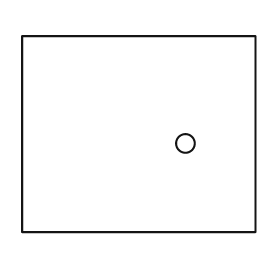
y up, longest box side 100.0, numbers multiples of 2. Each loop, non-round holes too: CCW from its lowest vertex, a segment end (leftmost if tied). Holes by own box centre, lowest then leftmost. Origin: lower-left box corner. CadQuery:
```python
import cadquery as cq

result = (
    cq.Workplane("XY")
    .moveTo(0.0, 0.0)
    .lineTo(100.0, 0.0)
    .lineTo(100.0, 84.0)
    .lineTo(0.0, 84.0)
    .close()
    .moveTo(70.0, 38.0)
    .circle(4.0)
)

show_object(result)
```